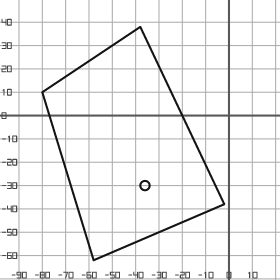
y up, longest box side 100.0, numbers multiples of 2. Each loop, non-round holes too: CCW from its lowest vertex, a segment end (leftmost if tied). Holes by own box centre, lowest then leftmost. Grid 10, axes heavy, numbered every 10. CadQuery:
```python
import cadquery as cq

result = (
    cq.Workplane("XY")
    .moveTo(-58.0, -62.0)
    .lineTo(-2.0, -38.0)
    .lineTo(-38.0, 38.0)
    .lineTo(-80.0, 10.0)
    .close()
    .moveTo(-36.0, -30.0)
    .circle(2.0)
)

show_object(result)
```